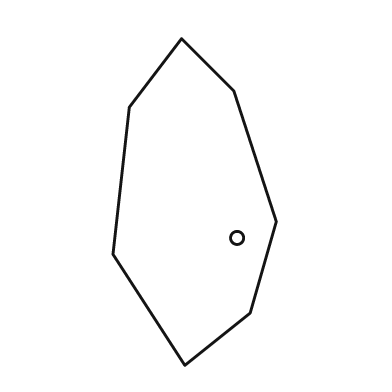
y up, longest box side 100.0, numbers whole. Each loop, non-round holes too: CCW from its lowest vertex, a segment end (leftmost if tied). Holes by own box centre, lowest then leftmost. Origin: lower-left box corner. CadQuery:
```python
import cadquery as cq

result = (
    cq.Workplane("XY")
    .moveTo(22.0, 0.0)
    .lineTo(42.0, 16.0)
    .lineTo(50.0, 44.0)
    .lineTo(37.0, 84.0)
    .lineTo(21.0, 100.0)
    .lineTo(5.0, 79.0)
    .lineTo(0.0, 34.0)
    .close()
    .moveTo(38.0, 39.0)
    .circle(2.0)
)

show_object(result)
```